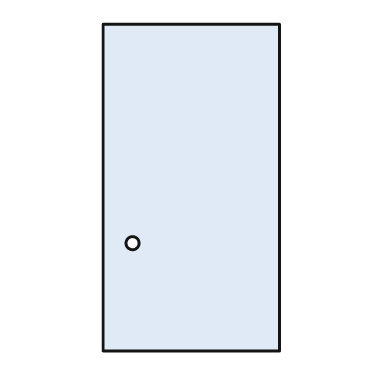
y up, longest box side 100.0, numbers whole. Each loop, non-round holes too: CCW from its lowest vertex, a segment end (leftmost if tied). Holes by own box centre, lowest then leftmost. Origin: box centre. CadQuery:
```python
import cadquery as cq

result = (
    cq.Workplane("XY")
    .moveTo(-27.0, -50.0)
    .lineTo(27.0, -50.0)
    .lineTo(27.0, 50.0)
    .lineTo(-27.0, 50.0)
    .close()
    .moveTo(-18.0, -17.0)
    .circle(2.0)
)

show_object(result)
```